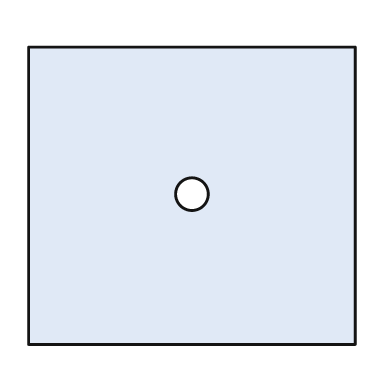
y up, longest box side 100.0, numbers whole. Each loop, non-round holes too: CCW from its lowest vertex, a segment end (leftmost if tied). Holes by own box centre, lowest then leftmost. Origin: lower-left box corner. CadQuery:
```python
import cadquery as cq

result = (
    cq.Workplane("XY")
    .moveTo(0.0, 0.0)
    .lineTo(100.0, 0.0)
    .lineTo(100.0, 91.0)
    .lineTo(0.0, 91.0)
    .close()
    .moveTo(50.0, 46.0)
    .circle(5.0)
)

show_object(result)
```